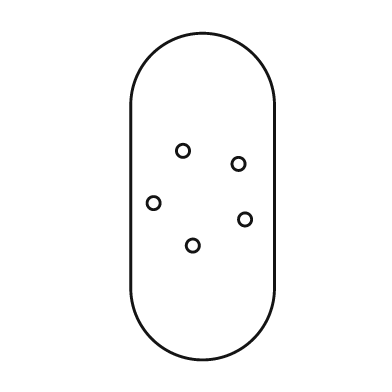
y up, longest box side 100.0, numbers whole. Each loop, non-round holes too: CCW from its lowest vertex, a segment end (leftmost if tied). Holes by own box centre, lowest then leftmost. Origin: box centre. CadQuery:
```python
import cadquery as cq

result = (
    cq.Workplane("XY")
    .moveTo(-22.0, -28.0)
    .threePointArc((0.0, -50.0), (22.0, -28.0))
    .lineTo(22.0, 28.0)
    .threePointArc((0.0, 50.0), (-22.0, 28.0))
    .close()
    .moveTo(-3.0, -15.0)
    .circle(2.0)
    .moveTo(13.0, -7.0)
    .circle(2.0)
    .moveTo(-15.0, -2.0)
    .circle(2.0)
    .moveTo(11.0, 10.0)
    .circle(2.0)
    .moveTo(-6.0, 14.0)
    .circle(2.0)
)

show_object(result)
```